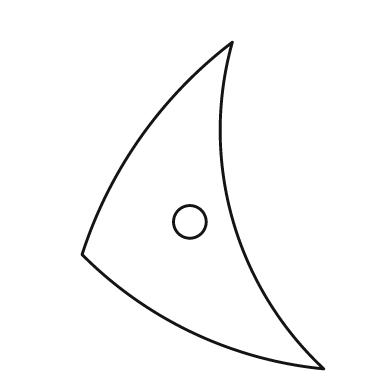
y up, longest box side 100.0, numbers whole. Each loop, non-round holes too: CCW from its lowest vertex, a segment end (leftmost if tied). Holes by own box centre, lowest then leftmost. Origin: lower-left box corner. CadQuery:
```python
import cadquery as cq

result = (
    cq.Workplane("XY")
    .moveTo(74.0, 0.0)
    .threePointArc((46.0, 46.0), (46.0, 100.0))
    .threePointArc((18.0, 71.0), (0.0, 35.0))
    .threePointArc((34.0, 11.0), (74.0, 0.0))
    .close()
    .moveTo(33.0, 45.0)
    .circle(5.0)
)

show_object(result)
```